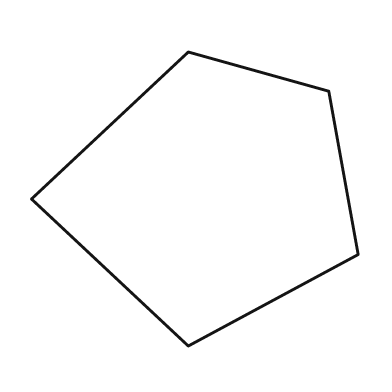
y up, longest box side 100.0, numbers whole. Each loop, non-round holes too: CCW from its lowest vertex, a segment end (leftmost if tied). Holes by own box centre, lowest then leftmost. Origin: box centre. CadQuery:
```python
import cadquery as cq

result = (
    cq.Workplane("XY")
    .moveTo(-2.0, -45.0)
    .lineTo(50.0, -17.0)
    .lineTo(41.0, 33.0)
    .lineTo(-2.0, 45.0)
    .lineTo(-50.0, 0.0)
    .close()
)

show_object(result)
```